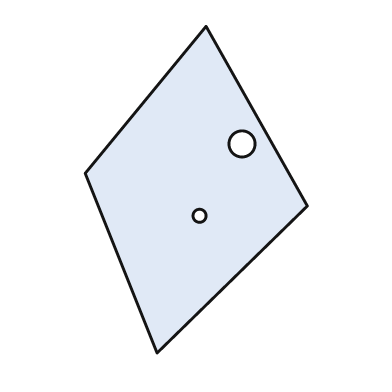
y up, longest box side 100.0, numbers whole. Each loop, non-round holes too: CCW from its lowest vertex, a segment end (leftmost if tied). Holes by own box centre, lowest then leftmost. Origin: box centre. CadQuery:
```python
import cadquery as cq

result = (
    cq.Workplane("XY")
    .moveTo(-12.0, -50.0)
    .lineTo(34.0, -5.0)
    .lineTo(3.0, 50.0)
    .lineTo(-34.0, 5.0)
    .close()
    .moveTo(1.0, -8.0)
    .circle(2.0)
    .moveTo(14.0, 14.0)
    .circle(4.0)
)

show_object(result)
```